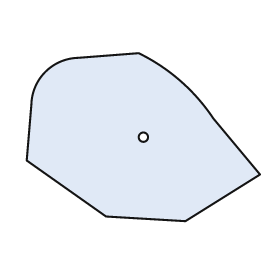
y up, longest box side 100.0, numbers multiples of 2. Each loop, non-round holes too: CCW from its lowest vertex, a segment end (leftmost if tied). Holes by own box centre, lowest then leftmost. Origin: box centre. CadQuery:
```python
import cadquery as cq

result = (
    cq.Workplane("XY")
    .moveTo(18.0, -36.0)
    .lineTo(50.0, -16.0)
    .lineTo(30.0, 8.0)
    .threePointArc((16.0, 24.0), (-2.0, 36.0))
    .lineTo(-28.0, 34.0)
    .threePointArc((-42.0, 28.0), (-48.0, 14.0))
    .lineTo(-50.0, -10.0)
    .lineTo(-16.0, -34.0)
    .close()
    .moveTo(0.0, 0.0)
    .circle(2.0)
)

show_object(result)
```